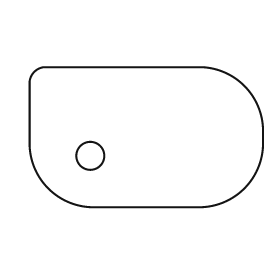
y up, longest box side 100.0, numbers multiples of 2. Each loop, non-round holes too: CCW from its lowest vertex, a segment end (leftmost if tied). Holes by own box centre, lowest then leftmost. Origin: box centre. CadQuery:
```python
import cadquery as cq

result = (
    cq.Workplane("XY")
    .moveTo(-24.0, -30.0)
    .lineTo(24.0, -30.0)
    .threePointArc((42.0, -22.0), (50.0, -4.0))
    .lineTo(50.0, 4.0)
    .threePointArc((42.0, 22.0), (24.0, 30.0))
    .lineTo(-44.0, 30.0)
    .threePointArc((-48.0, 28.0), (-50.0, 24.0))
    .lineTo(-50.0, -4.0)
    .threePointArc((-42.0, -22.0), (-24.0, -30.0))
    .close()
    .moveTo(-24.0, -8.0)
    .circle(6.0)
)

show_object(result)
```